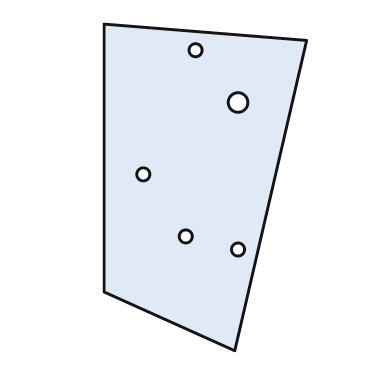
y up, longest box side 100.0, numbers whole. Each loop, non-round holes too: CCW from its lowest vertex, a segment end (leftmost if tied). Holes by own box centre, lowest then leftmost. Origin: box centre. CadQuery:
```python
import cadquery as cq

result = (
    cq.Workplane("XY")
    .moveTo(9.0, -50.0)
    .lineTo(31.0, 45.0)
    .lineTo(-31.0, 50.0)
    .lineTo(-31.0, -32.0)
    .close()
    .moveTo(10.0, -19.0)
    .circle(2.0)
    .moveTo(-6.0, -15.0)
    .circle(2.0)
    .moveTo(-19.0, 4.0)
    .circle(2.0)
    .moveTo(10.0, 26.0)
    .circle(3.0)
    .moveTo(-3.0, 42.0)
    .circle(2.0)
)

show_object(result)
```